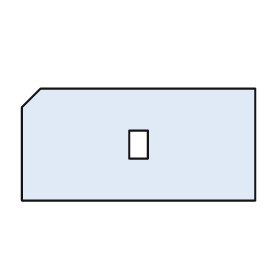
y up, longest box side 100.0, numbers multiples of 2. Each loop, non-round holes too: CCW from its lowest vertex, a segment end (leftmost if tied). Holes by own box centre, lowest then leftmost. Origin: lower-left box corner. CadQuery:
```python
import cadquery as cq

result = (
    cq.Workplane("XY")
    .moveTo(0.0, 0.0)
    .lineTo(100.0, 0.0)
    .lineTo(100.0, 48.0)
    .lineTo(8.0, 48.0)
    .lineTo(0.0, 40.0)
    .close()
    .moveTo(46.0, 18.0)
    .lineTo(54.0, 18.0)
    .lineTo(54.0, 30.0)
    .lineTo(46.0, 30.0)
    .close()
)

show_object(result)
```